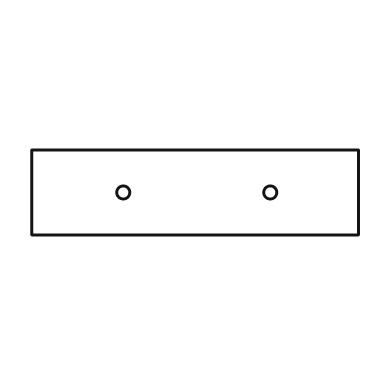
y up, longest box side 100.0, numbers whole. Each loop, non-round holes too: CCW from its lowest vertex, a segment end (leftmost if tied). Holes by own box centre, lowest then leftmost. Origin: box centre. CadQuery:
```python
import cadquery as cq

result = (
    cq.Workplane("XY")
    .moveTo(-50.0, -13.0)
    .lineTo(50.0, -13.0)
    .lineTo(50.0, 13.0)
    .lineTo(-50.0, 13.0)
    .close()
    .moveTo(-22.0, 0.0)
    .circle(2.0)
    .moveTo(23.0, 0.0)
    .circle(2.0)
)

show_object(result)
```